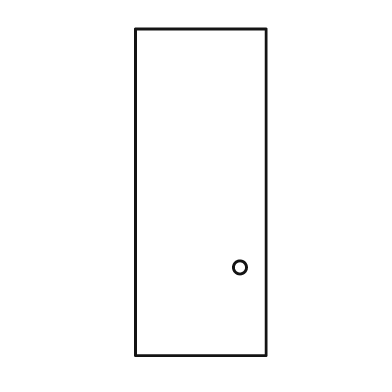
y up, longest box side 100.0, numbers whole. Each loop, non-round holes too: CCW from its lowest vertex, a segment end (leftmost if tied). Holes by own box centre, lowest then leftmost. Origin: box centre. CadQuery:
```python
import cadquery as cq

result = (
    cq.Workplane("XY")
    .moveTo(-20.0, -50.0)
    .lineTo(20.0, -50.0)
    .lineTo(20.0, 50.0)
    .lineTo(-20.0, 50.0)
    .close()
    .moveTo(12.0, -23.0)
    .circle(2.0)
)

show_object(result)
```